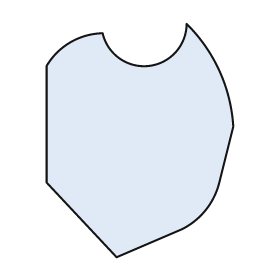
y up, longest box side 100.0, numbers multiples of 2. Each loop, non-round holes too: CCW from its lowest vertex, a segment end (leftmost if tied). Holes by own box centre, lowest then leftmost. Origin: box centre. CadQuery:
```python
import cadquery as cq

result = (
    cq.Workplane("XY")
    .moveTo(-10.0, -50.0)
    .lineTo(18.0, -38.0)
    .threePointArc((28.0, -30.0), (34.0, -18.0))
    .lineTo(40.0, 6.0)
    .threePointArc((34.0, 30.0), (20.0, 50.0))
    .threePointArc((4.0, 32.0), (-16.0, 46.0))
    .threePointArc((-30.0, 42.0), (-40.0, 32.0))
    .lineTo(-40.0, -18.0)
    .close()
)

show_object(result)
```